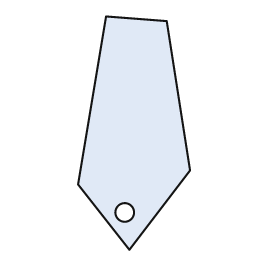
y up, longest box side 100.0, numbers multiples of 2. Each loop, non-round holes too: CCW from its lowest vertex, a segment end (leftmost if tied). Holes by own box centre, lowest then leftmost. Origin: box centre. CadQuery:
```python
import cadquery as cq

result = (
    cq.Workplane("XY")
    .moveTo(-2.0, -50.0)
    .lineTo(24.0, -16.0)
    .lineTo(14.0, 48.0)
    .lineTo(-12.0, 50.0)
    .lineTo(-24.0, -22.0)
    .close()
    .moveTo(-4.0, -34.0)
    .circle(4.0)
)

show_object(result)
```